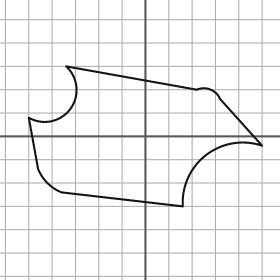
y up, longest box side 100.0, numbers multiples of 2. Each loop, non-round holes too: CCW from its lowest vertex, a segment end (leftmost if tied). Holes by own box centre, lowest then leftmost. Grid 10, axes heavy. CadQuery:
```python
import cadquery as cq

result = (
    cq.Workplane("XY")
    .moveTo(16.0, -30.0)
    .threePointArc((26.0, -8.0), (50.0, -4.0))
    .lineTo(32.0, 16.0)
    .threePointArc((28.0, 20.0), (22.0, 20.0))
    .lineTo(-34.0, 30.0)
    .threePointArc((-32.0, 12.0), (-50.0, 8.0))
    .lineTo(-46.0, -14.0)
    .threePointArc((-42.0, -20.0), (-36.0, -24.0))
    .close()
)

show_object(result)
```